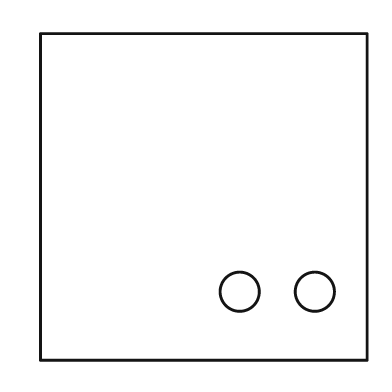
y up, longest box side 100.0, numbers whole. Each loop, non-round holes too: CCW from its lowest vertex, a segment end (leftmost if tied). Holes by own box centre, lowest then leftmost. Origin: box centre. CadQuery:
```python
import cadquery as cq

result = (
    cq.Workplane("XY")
    .moveTo(-50.0, -50.0)
    .lineTo(50.0, -50.0)
    .lineTo(50.0, 50.0)
    .lineTo(-50.0, 50.0)
    .close()
    .moveTo(11.0, -29.0)
    .circle(6.0)
    .moveTo(34.0, -29.0)
    .circle(6.0)
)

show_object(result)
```